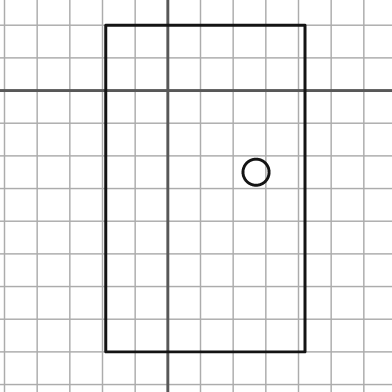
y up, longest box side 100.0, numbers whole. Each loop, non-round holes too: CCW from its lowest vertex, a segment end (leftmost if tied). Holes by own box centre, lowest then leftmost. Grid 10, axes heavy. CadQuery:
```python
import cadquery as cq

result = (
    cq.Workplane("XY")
    .moveTo(-19.0, -80.0)
    .lineTo(42.0, -80.0)
    .lineTo(42.0, 20.0)
    .lineTo(-19.0, 20.0)
    .close()
    .moveTo(27.0, -25.0)
    .circle(4.0)
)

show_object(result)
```